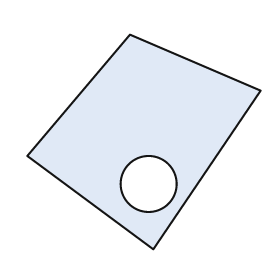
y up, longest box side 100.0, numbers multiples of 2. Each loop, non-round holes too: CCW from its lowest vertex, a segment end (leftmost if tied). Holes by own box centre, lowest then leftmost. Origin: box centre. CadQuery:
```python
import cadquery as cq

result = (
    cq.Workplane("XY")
    .moveTo(4.0, -46.0)
    .lineTo(50.0, 22.0)
    .lineTo(-6.0, 46.0)
    .lineTo(-50.0, -6.0)
    .close()
    .moveTo(2.0, -18.0)
    .circle(12.0)
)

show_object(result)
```